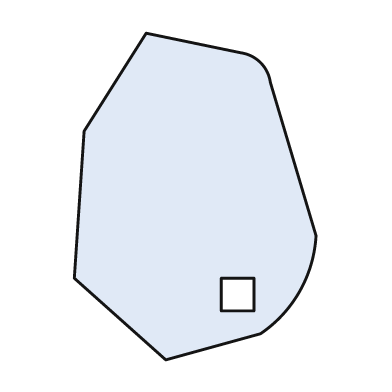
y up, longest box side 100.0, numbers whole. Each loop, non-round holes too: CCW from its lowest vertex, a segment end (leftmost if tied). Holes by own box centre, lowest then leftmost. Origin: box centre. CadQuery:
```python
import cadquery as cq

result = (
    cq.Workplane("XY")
    .moveTo(-9.0, -50.0)
    .lineTo(20.0, -42.0)
    .threePointArc((32.0, -29.0), (37.0, -12.0))
    .lineTo(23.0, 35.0)
    .threePointArc((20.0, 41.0), (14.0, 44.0))
    .lineTo(-15.0, 50.0)
    .lineTo(-34.0, 20.0)
    .lineTo(-37.0, -25.0)
    .close()
    .moveTo(8.0, -35.0)
    .lineTo(18.0, -35.0)
    .lineTo(18.0, -25.0)
    .lineTo(8.0, -25.0)
    .close()
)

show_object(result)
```